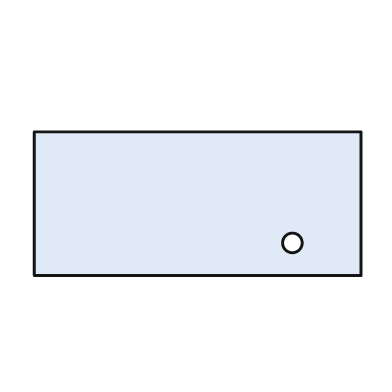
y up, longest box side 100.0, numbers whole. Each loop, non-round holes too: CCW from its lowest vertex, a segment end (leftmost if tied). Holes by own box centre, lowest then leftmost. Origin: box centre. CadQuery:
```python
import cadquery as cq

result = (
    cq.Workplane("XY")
    .moveTo(-50.0, -22.0)
    .lineTo(50.0, -22.0)
    .lineTo(50.0, 22.0)
    .lineTo(-50.0, 22.0)
    .close()
    .moveTo(29.0, -12.0)
    .circle(3.0)
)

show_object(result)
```